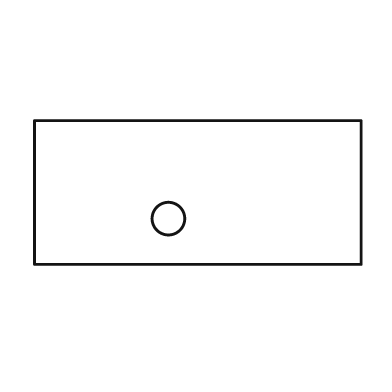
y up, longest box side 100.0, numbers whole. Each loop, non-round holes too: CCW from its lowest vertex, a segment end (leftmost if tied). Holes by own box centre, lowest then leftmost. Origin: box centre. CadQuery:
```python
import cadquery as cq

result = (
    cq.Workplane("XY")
    .moveTo(-50.0, -22.0)
    .lineTo(50.0, -22.0)
    .lineTo(50.0, 22.0)
    .lineTo(-50.0, 22.0)
    .close()
    .moveTo(-9.0, -8.0)
    .circle(5.0)
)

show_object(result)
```